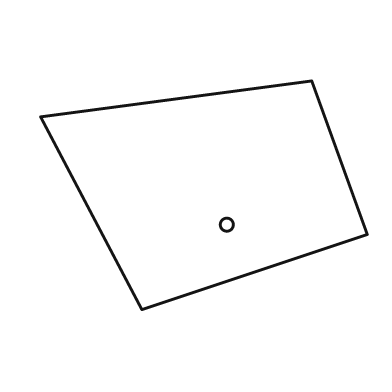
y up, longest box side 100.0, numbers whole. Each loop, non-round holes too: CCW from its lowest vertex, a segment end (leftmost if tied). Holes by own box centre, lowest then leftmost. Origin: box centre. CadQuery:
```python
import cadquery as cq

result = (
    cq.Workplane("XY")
    .moveTo(-19.0, -35.0)
    .lineTo(50.0, -12.0)
    .lineTo(33.0, 35.0)
    .lineTo(-50.0, 24.0)
    .close()
    .moveTo(7.0, -9.0)
    .circle(2.0)
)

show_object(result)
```